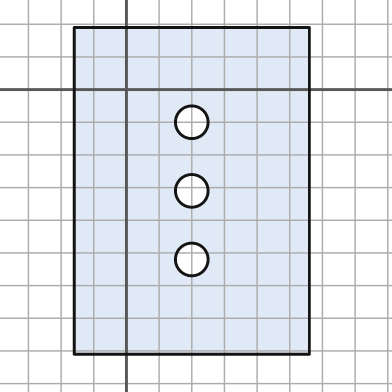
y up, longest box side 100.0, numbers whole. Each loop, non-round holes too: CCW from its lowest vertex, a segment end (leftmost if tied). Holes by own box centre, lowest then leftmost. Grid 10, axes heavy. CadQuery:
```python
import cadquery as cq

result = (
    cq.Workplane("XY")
    .moveTo(-16.0, -81.0)
    .lineTo(56.0, -81.0)
    .lineTo(56.0, 19.0)
    .lineTo(-16.0, 19.0)
    .close()
    .moveTo(20.0, -52.0)
    .circle(5.0)
    .moveTo(20.0, -31.0)
    .circle(5.0)
    .moveTo(20.0, -10.0)
    .circle(5.0)
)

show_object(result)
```